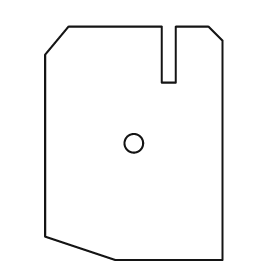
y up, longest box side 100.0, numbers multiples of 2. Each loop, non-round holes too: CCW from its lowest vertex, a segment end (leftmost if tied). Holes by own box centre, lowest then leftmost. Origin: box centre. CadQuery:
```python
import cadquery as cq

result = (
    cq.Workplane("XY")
    .moveTo(-8.0, -50.0)
    .lineTo(38.0, -50.0)
    .lineTo(38.0, 44.0)
    .lineTo(32.0, 50.0)
    .lineTo(18.0, 50.0)
    .lineTo(18.0, 26.0)
    .lineTo(12.0, 26.0)
    .lineTo(12.0, 50.0)
    .lineTo(-28.0, 50.0)
    .lineTo(-38.0, 38.0)
    .lineTo(-38.0, -40.0)
    .close()
    .moveTo(0.0, 0.0)
    .circle(4.0)
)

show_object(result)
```